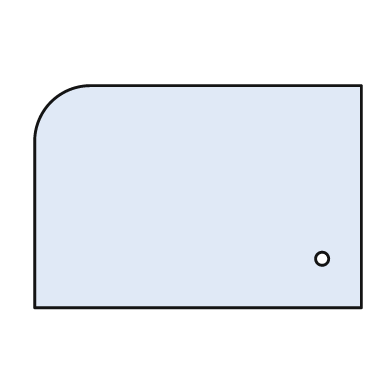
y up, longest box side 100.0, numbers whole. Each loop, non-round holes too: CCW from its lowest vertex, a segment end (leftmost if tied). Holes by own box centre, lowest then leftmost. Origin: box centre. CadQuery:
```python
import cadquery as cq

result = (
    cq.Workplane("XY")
    .moveTo(-50.0, -34.0)
    .lineTo(50.0, -34.0)
    .lineTo(50.0, 34.0)
    .lineTo(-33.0, 34.0)
    .threePointArc((-45.0, 29.0), (-50.0, 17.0))
    .close()
    .moveTo(38.0, -19.0)
    .circle(2.0)
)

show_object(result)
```